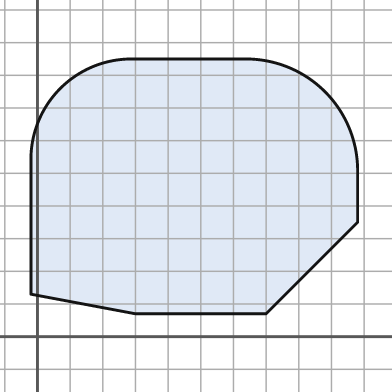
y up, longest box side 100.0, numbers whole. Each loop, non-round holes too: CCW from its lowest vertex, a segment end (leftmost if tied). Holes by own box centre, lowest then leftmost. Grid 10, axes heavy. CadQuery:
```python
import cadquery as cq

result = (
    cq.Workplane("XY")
    .moveTo(30.0, 7.0)
    .lineTo(70.0, 7.0)
    .lineTo(98.0, 35.0)
    .lineTo(98.0, 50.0)
    .threePointArc((88.0, 75.0), (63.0, 85.0))
    .lineTo(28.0, 85.0)
    .threePointArc((7.0, 76.0), (-2.0, 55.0))
    .lineTo(-2.0, 13.0)
    .close()
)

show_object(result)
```